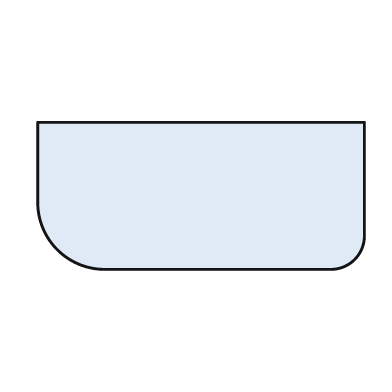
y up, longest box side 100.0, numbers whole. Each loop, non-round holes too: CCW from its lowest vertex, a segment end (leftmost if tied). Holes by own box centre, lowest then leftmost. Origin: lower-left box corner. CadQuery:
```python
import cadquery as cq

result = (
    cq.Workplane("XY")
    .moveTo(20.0, 0.0)
    .lineTo(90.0, 0.0)
    .threePointArc((97.0, 3.0), (100.0, 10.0))
    .lineTo(100.0, 45.0)
    .lineTo(0.0, 45.0)
    .lineTo(0.0, 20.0)
    .threePointArc((6.0, 6.0), (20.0, 0.0))
    .close()
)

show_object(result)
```